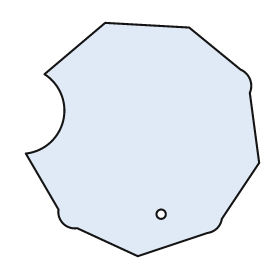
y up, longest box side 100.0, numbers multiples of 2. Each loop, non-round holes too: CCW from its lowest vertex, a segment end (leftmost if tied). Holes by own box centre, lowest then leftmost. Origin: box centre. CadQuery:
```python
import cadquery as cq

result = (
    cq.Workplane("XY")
    .moveTo(-2.0, -50.0)
    .lineTo(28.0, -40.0)
    .threePointArc((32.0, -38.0), (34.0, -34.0))
    .lineTo(50.0, -10.0)
    .lineTo(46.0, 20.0)
    .threePointArc((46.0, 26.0), (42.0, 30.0))
    .lineTo(20.0, 48.0)
    .lineTo(-16.0, 50.0)
    .lineTo(-42.0, 28.0)
    .threePointArc((-34.0, 8.0), (-50.0, -6.0))
    .lineTo(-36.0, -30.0)
    .threePointArc((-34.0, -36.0), (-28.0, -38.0))
    .close()
    .moveTo(8.0, -32.0)
    .circle(2.0)
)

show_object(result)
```